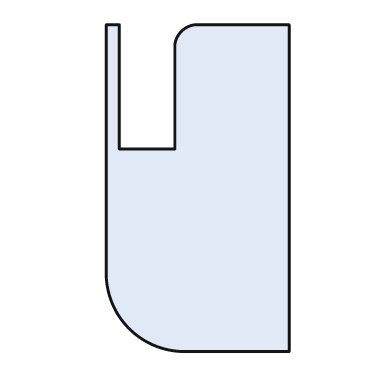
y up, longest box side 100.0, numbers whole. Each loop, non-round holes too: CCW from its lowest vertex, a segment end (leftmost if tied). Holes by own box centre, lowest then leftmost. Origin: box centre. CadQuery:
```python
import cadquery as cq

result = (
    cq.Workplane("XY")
    .moveTo(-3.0, -50.0)
    .lineTo(28.0, -50.0)
    .lineTo(28.0, 50.0)
    .lineTo(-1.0, 50.0)
    .threePointArc((-5.0, 48.0), (-7.0, 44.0))
    .lineTo(-7.0, 12.0)
    .lineTo(-24.0, 12.0)
    .lineTo(-24.0, 50.0)
    .lineTo(-28.0, 50.0)
    .lineTo(-28.0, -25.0)
    .threePointArc((-21.0, -43.0), (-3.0, -50.0))
    .close()
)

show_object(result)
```